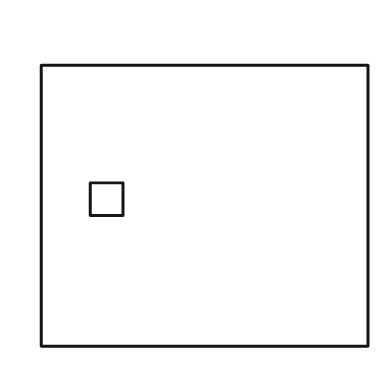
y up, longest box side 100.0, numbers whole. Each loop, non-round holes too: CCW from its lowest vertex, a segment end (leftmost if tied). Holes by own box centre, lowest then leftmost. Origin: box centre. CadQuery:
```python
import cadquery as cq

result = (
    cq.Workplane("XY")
    .moveTo(-50.0, -43.0)
    .lineTo(50.0, -43.0)
    .lineTo(50.0, 43.0)
    .lineTo(-50.0, 43.0)
    .close()
    .moveTo(-35.0, -3.0)
    .lineTo(-25.0, -3.0)
    .lineTo(-25.0, 7.0)
    .lineTo(-35.0, 7.0)
    .close()
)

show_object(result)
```